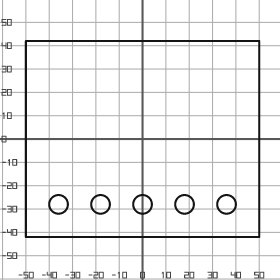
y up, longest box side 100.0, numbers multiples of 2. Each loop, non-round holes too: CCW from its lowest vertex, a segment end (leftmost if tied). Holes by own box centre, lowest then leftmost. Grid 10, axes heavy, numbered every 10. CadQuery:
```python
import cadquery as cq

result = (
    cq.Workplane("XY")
    .moveTo(-50.0, -42.0)
    .lineTo(50.0, -42.0)
    .lineTo(50.0, 42.0)
    .lineTo(-50.0, 42.0)
    .close()
    .moveTo(-36.0, -28.0)
    .circle(4.0)
    .moveTo(-18.0, -28.0)
    .circle(4.0)
    .moveTo(0.0, -28.0)
    .circle(4.0)
    .moveTo(18.0, -28.0)
    .circle(4.0)
    .moveTo(36.0, -28.0)
    .circle(4.0)
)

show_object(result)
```